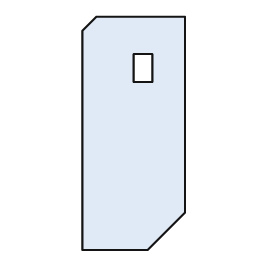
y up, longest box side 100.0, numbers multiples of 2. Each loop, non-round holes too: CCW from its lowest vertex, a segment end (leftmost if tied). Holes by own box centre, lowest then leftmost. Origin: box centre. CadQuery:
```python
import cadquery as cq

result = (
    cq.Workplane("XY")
    .moveTo(-22.0, -50.0)
    .lineTo(6.0, -50.0)
    .lineTo(22.0, -34.0)
    .lineTo(22.0, 50.0)
    .lineTo(-16.0, 50.0)
    .lineTo(-22.0, 44.0)
    .close()
    .moveTo(0.0, 22.0)
    .lineTo(8.0, 22.0)
    .lineTo(8.0, 34.0)
    .lineTo(0.0, 34.0)
    .close()
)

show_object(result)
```